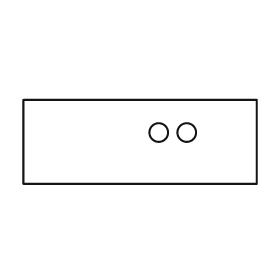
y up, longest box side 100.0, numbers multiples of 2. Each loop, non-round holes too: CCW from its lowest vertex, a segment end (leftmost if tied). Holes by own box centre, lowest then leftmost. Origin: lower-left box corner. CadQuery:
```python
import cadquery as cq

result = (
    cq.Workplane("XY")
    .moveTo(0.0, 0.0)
    .lineTo(100.0, 0.0)
    .lineTo(100.0, 36.0)
    .lineTo(0.0, 36.0)
    .close()
    .moveTo(58.0, 22.0)
    .circle(4.0)
    .moveTo(70.0, 22.0)
    .circle(4.0)
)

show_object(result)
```